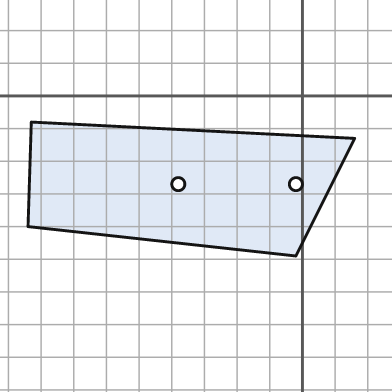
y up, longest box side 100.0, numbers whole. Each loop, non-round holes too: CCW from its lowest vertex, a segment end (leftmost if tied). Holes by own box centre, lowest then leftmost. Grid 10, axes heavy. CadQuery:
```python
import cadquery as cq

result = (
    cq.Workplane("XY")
    .moveTo(-2.0, -49.0)
    .lineTo(16.0, -13.0)
    .lineTo(-83.0, -8.0)
    .lineTo(-84.0, -40.0)
    .close()
    .moveTo(-38.0, -27.0)
    .circle(2.0)
    .moveTo(-2.0, -27.0)
    .circle(2.0)
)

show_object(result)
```